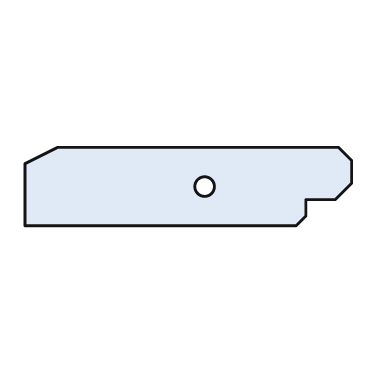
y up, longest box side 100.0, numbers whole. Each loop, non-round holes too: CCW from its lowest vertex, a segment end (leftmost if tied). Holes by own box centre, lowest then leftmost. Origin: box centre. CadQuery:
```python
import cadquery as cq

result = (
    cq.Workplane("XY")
    .moveTo(-50.0, -12.0)
    .lineTo(33.0, -12.0)
    .lineTo(36.0, -9.0)
    .lineTo(36.0, -4.0)
    .lineTo(45.0, -4.0)
    .lineTo(50.0, 1.0)
    .lineTo(50.0, 8.0)
    .lineTo(46.0, 12.0)
    .lineTo(-40.0, 12.0)
    .lineTo(-50.0, 7.0)
    .close()
    .moveTo(5.0, 0.0)
    .circle(3.0)
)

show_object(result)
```